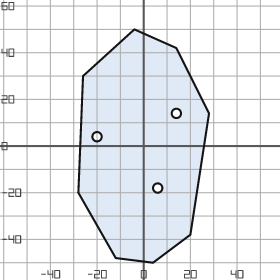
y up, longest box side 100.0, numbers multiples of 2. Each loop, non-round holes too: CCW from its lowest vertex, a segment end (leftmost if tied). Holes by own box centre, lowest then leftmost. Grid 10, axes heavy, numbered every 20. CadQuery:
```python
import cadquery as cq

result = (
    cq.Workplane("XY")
    .moveTo(4.0, -50.0)
    .lineTo(20.0, -38.0)
    .lineTo(28.0, 14.0)
    .lineTo(14.0, 42.0)
    .lineTo(-4.0, 50.0)
    .lineTo(-26.0, 30.0)
    .lineTo(-28.0, -20.0)
    .lineTo(-12.0, -48.0)
    .close()
    .moveTo(6.0, -18.0)
    .circle(2.0)
    .moveTo(-20.0, 4.0)
    .circle(2.0)
    .moveTo(14.0, 14.0)
    .circle(2.0)
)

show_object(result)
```